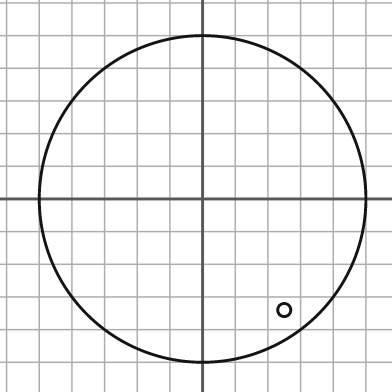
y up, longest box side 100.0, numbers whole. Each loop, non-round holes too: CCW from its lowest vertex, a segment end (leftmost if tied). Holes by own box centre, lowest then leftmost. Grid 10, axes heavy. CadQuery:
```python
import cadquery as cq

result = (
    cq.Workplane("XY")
    .moveTo(0.0, 0.0)
    .circle(50.0)
    .moveTo(25.0, -34.0)
    .circle(2.0)
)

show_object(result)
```